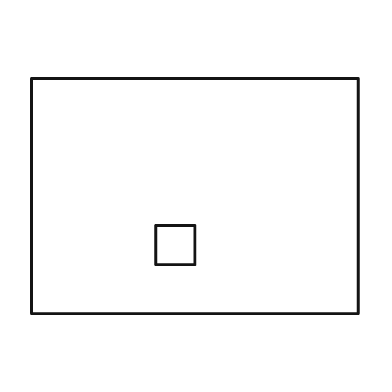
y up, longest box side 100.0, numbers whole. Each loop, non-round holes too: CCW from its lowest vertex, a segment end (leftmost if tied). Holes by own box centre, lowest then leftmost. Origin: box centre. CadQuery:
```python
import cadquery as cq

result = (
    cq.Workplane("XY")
    .moveTo(-50.0, -36.0)
    .lineTo(50.0, -36.0)
    .lineTo(50.0, 36.0)
    .lineTo(-50.0, 36.0)
    .close()
    .moveTo(-12.0, -21.0)
    .lineTo(0.0, -21.0)
    .lineTo(0.0, -9.0)
    .lineTo(-12.0, -9.0)
    .close()
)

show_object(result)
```